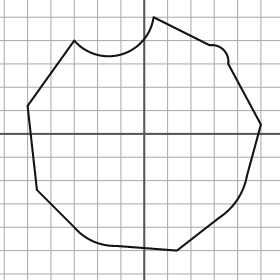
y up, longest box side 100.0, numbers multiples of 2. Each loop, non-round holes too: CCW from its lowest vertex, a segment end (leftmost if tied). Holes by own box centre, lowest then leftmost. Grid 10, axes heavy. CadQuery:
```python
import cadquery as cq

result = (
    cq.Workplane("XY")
    .moveTo(14.0, -50.0)
    .lineTo(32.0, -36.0)
    .threePointArc((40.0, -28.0), (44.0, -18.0))
    .lineTo(50.0, 4.0)
    .lineTo(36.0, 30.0)
    .threePointArc((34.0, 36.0), (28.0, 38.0))
    .lineTo(4.0, 50.0)
    .threePointArc((-10.0, 34.0), (-30.0, 40.0))
    .lineTo(-50.0, 12.0)
    .lineTo(-46.0, -24.0)
    .lineTo(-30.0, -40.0)
    .threePointArc((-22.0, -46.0), (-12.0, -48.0))
    .close()
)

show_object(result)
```